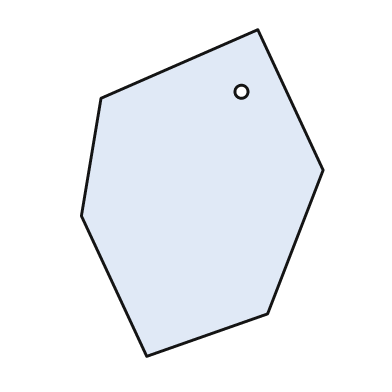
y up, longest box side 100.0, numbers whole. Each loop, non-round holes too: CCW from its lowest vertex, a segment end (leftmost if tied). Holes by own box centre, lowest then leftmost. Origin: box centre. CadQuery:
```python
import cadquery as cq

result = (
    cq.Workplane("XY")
    .moveTo(-17.0, -50.0)
    .lineTo(20.0, -37.0)
    .lineTo(37.0, 7.0)
    .lineTo(17.0, 50.0)
    .lineTo(-31.0, 29.0)
    .lineTo(-37.0, -7.0)
    .close()
    .moveTo(12.0, 31.0)
    .circle(2.0)
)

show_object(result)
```